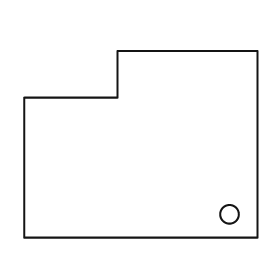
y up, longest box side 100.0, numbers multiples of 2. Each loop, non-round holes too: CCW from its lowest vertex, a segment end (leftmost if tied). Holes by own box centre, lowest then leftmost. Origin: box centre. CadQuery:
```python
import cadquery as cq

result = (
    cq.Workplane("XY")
    .moveTo(-50.0, -40.0)
    .lineTo(50.0, -40.0)
    .lineTo(50.0, 40.0)
    .lineTo(-10.0, 40.0)
    .lineTo(-10.0, 20.0)
    .lineTo(-50.0, 20.0)
    .close()
    .moveTo(38.0, -30.0)
    .circle(4.0)
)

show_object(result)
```